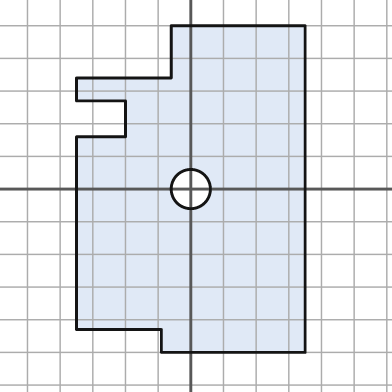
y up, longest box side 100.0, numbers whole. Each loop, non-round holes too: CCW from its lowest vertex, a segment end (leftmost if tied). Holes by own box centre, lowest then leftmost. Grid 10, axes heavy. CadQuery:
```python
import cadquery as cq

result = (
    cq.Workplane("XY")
    .moveTo(-9.0, -50.0)
    .lineTo(35.0, -50.0)
    .lineTo(35.0, 50.0)
    .lineTo(-6.0, 50.0)
    .lineTo(-6.0, 34.0)
    .lineTo(-35.0, 34.0)
    .lineTo(-35.0, 27.0)
    .lineTo(-20.0, 27.0)
    .lineTo(-20.0, 16.0)
    .lineTo(-35.0, 16.0)
    .lineTo(-35.0, -43.0)
    .lineTo(-9.0, -43.0)
    .close()
    .moveTo(0.0, 0.0)
    .circle(6.0)
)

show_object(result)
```